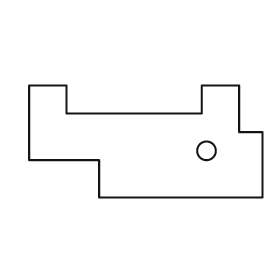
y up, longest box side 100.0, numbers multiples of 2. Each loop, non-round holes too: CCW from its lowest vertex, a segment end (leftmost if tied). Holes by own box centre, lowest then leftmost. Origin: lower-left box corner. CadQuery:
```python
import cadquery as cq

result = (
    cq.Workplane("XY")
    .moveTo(30.0, 0.0)
    .lineTo(100.0, 0.0)
    .lineTo(100.0, 28.0)
    .lineTo(90.0, 28.0)
    .lineTo(90.0, 48.0)
    .lineTo(74.0, 48.0)
    .lineTo(74.0, 36.0)
    .lineTo(16.0, 36.0)
    .lineTo(16.0, 48.0)
    .lineTo(0.0, 48.0)
    .lineTo(0.0, 16.0)
    .lineTo(30.0, 16.0)
    .close()
    .moveTo(76.0, 20.0)
    .circle(4.0)
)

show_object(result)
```